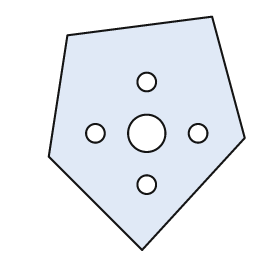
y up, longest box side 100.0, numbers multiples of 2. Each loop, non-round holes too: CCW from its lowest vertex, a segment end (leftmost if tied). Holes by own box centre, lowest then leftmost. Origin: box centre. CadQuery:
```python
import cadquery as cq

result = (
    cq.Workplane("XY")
    .moveTo(-2.0, -50.0)
    .lineTo(42.0, -2.0)
    .lineTo(28.0, 50.0)
    .lineTo(-34.0, 42.0)
    .lineTo(-42.0, -10.0)
    .close()
    .moveTo(0.0, -22.0)
    .circle(4.0)
    .moveTo(-22.0, 0.0)
    .circle(4.0)
    .moveTo(0.0, 0.0)
    .circle(8.0)
    .moveTo(22.0, 0.0)
    .circle(4.0)
    .moveTo(0.0, 22.0)
    .circle(4.0)
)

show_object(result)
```